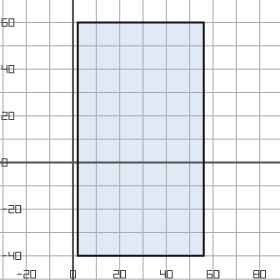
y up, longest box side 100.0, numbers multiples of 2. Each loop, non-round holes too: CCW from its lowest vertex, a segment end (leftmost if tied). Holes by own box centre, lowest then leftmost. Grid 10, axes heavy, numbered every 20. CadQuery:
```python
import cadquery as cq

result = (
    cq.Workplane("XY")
    .moveTo(2.0, -40.0)
    .lineTo(56.0, -40.0)
    .lineTo(56.0, 60.0)
    .lineTo(2.0, 60.0)
    .close()
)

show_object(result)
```